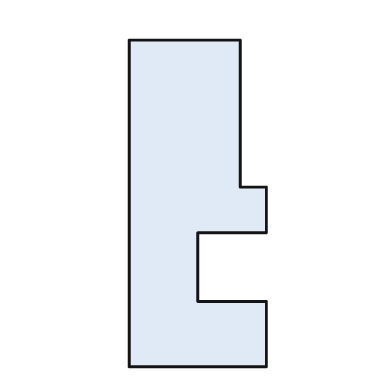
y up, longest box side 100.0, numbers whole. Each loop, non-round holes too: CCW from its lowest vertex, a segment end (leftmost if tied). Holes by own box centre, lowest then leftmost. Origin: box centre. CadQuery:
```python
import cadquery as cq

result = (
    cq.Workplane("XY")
    .moveTo(-21.0, -50.0)
    .lineTo(21.0, -50.0)
    .lineTo(21.0, -30.0)
    .lineTo(0.0, -30.0)
    .lineTo(0.0, -9.0)
    .lineTo(21.0, -9.0)
    .lineTo(21.0, 5.0)
    .lineTo(13.0, 5.0)
    .lineTo(13.0, 50.0)
    .lineTo(-21.0, 50.0)
    .close()
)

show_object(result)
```